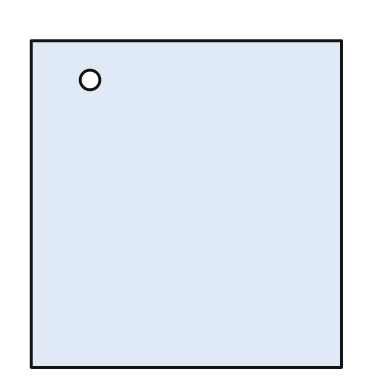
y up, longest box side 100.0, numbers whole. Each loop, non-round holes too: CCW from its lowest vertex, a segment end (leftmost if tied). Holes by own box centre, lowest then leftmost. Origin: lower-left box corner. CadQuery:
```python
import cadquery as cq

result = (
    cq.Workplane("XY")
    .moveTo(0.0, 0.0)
    .lineTo(95.0, 0.0)
    .lineTo(95.0, 100.0)
    .lineTo(0.0, 100.0)
    .close()
    .moveTo(18.0, 88.0)
    .circle(3.0)
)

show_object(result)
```